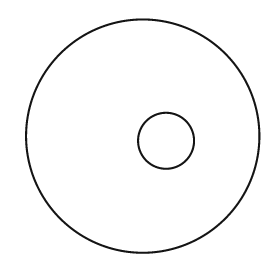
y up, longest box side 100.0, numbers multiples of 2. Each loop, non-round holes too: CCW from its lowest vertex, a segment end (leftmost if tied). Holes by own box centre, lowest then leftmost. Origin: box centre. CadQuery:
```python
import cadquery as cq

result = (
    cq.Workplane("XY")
    .moveTo(0.0, 0.0)
    .circle(50.0)
    .moveTo(10.0, -2.0)
    .circle(12.0)
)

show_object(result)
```